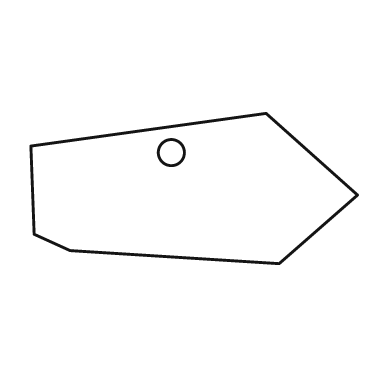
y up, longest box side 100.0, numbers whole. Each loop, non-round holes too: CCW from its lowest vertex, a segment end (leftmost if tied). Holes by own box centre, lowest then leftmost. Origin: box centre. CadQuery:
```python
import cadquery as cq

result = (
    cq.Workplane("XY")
    .moveTo(26.0, -23.0)
    .lineTo(50.0, -2.0)
    .lineTo(22.0, 23.0)
    .lineTo(-50.0, 13.0)
    .lineTo(-49.0, -14.0)
    .lineTo(-38.0, -19.0)
    .close()
    .moveTo(-7.0, 11.0)
    .circle(4.0)
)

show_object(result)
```